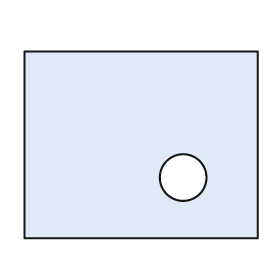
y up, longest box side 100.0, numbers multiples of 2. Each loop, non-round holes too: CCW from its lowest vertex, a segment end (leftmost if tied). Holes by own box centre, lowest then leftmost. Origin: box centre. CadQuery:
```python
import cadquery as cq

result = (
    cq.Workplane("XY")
    .moveTo(-50.0, -40.0)
    .lineTo(50.0, -40.0)
    .lineTo(50.0, 40.0)
    .lineTo(-50.0, 40.0)
    .close()
    .moveTo(18.0, -14.0)
    .circle(10.0)
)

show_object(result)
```